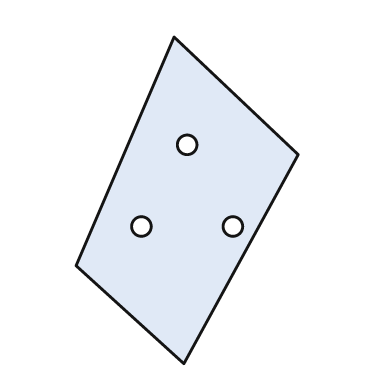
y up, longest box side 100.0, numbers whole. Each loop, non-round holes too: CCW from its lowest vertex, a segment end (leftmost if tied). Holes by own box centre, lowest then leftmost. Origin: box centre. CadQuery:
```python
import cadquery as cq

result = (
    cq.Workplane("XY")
    .moveTo(-1.0, -50.0)
    .lineTo(34.0, 14.0)
    .lineTo(-4.0, 50.0)
    .lineTo(-34.0, -20.0)
    .close()
    .moveTo(-14.0, -8.0)
    .circle(3.0)
    .moveTo(14.0, -8.0)
    .circle(3.0)
    .moveTo(0.0, 17.0)
    .circle(3.0)
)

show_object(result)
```